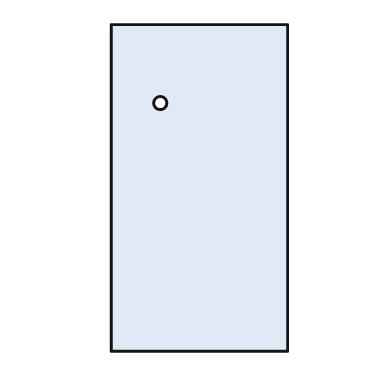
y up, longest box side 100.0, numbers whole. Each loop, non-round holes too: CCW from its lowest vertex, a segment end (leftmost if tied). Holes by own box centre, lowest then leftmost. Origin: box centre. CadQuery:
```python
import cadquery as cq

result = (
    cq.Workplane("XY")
    .moveTo(-27.0, -50.0)
    .lineTo(27.0, -50.0)
    .lineTo(27.0, 50.0)
    .lineTo(-27.0, 50.0)
    .close()
    .moveTo(-12.0, 26.0)
    .circle(2.0)
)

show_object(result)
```